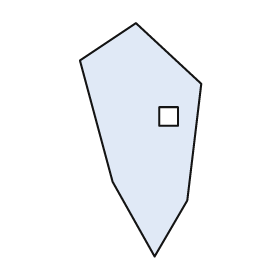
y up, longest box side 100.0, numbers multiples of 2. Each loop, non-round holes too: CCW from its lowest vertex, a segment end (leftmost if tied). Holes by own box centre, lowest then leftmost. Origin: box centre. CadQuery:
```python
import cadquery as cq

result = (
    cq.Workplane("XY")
    .moveTo(6.0, -50.0)
    .lineTo(20.0, -26.0)
    .lineTo(26.0, 24.0)
    .lineTo(-2.0, 50.0)
    .lineTo(-26.0, 34.0)
    .lineTo(-12.0, -18.0)
    .close()
    .moveTo(8.0, 6.0)
    .lineTo(16.0, 6.0)
    .lineTo(16.0, 14.0)
    .lineTo(8.0, 14.0)
    .close()
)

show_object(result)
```